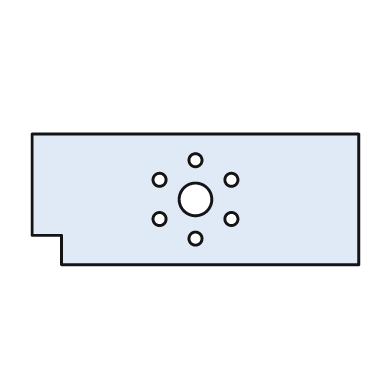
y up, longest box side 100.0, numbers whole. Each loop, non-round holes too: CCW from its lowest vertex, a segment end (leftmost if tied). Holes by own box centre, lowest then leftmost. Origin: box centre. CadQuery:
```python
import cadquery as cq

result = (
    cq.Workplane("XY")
    .moveTo(-41.0, -20.0)
    .lineTo(50.0, -20.0)
    .lineTo(50.0, 20.0)
    .lineTo(-50.0, 20.0)
    .lineTo(-50.0, -11.0)
    .lineTo(-41.0, -11.0)
    .close()
    .moveTo(0.0, -12.0)
    .circle(2.0)
    .moveTo(-11.0, -6.0)
    .circle(2.0)
    .moveTo(11.0, -6.0)
    .circle(2.0)
    .moveTo(0.0, 0.0)
    .circle(5.0)
    .moveTo(-11.0, 6.0)
    .circle(2.0)
    .moveTo(11.0, 6.0)
    .circle(2.0)
    .moveTo(0.0, 12.0)
    .circle(2.0)
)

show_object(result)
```